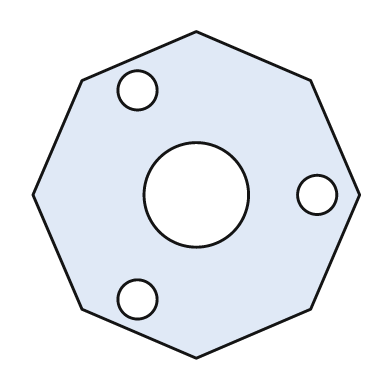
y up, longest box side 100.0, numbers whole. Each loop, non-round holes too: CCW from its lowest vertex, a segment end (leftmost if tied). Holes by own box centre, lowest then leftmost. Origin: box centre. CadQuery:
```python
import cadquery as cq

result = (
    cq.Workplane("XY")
    .moveTo(0.0, -50.0)
    .lineTo(35.0, -35.0)
    .lineTo(50.0, 0.0)
    .lineTo(35.0, 35.0)
    .lineTo(0.0, 50.0)
    .lineTo(-35.0, 35.0)
    .lineTo(-50.0, 0.0)
    .lineTo(-35.0, -35.0)
    .close()
    .moveTo(-18.0, -32.0)
    .circle(6.0)
    .moveTo(0.0, 0.0)
    .circle(16.0)
    .moveTo(37.0, 0.0)
    .circle(6.0)
    .moveTo(-18.0, 32.0)
    .circle(6.0)
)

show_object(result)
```